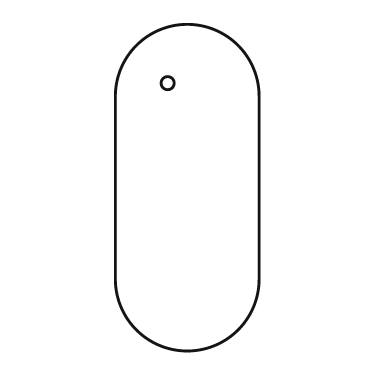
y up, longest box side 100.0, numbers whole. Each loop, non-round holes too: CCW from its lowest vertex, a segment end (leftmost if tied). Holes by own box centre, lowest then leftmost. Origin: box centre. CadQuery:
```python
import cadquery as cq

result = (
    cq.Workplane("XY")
    .moveTo(-22.0, -28.0)
    .threePointArc((0.0, -50.0), (22.0, -28.0))
    .lineTo(22.0, 28.0)
    .threePointArc((0.0, 50.0), (-22.0, 28.0))
    .close()
    .moveTo(-6.0, 32.0)
    .circle(2.0)
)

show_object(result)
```